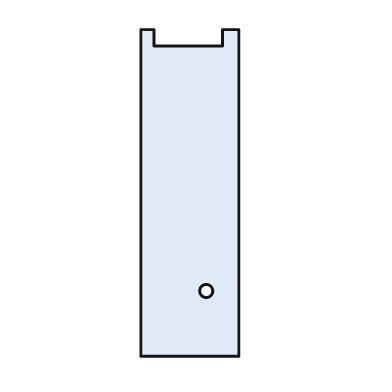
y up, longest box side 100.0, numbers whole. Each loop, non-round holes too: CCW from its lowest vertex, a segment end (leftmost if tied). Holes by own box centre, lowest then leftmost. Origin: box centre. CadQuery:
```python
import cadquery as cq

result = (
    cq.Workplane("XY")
    .moveTo(-15.0, -50.0)
    .lineTo(15.0, -50.0)
    .lineTo(15.0, 50.0)
    .lineTo(10.0, 50.0)
    .lineTo(10.0, 45.0)
    .lineTo(-11.0, 45.0)
    .lineTo(-11.0, 50.0)
    .lineTo(-15.0, 50.0)
    .close()
    .moveTo(5.0, -30.0)
    .circle(2.0)
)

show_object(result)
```